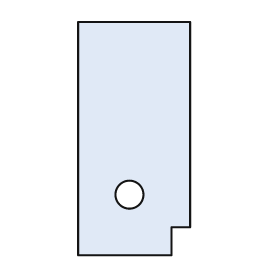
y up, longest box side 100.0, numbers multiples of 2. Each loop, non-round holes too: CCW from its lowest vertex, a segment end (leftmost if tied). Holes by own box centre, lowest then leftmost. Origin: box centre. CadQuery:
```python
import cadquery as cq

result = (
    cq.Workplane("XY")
    .moveTo(-24.0, -50.0)
    .lineTo(16.0, -50.0)
    .lineTo(16.0, -38.0)
    .lineTo(24.0, -38.0)
    .lineTo(24.0, 50.0)
    .lineTo(-24.0, 50.0)
    .close()
    .moveTo(-2.0, -24.0)
    .circle(6.0)
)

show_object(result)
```